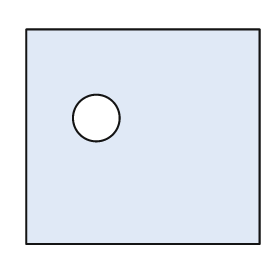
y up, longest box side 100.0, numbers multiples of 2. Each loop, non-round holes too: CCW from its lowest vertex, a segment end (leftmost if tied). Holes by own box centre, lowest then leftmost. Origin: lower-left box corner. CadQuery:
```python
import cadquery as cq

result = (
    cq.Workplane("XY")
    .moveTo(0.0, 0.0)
    .lineTo(100.0, 0.0)
    .lineTo(100.0, 92.0)
    .lineTo(0.0, 92.0)
    .close()
    .moveTo(30.0, 54.0)
    .circle(10.0)
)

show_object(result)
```